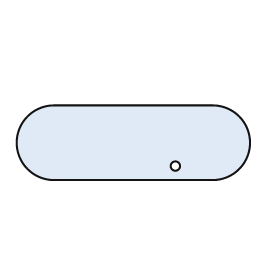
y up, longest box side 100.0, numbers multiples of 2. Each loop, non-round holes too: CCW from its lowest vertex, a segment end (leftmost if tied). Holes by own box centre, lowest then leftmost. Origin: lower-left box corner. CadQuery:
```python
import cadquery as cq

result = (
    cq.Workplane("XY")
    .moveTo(16.0, 0.0)
    .lineTo(84.0, 0.0)
    .threePointArc((100.0, 16.0), (84.0, 32.0))
    .lineTo(16.0, 32.0)
    .threePointArc((0.0, 16.0), (16.0, 0.0))
    .close()
    .moveTo(68.0, 6.0)
    .circle(2.0)
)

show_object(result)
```